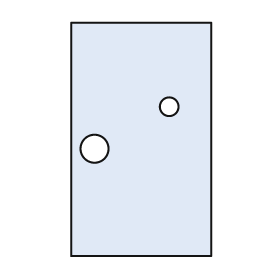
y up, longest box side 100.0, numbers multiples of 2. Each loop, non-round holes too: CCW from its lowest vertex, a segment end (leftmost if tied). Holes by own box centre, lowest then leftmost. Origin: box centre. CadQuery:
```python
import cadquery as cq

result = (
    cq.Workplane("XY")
    .moveTo(-30.0, -50.0)
    .lineTo(30.0, -50.0)
    .lineTo(30.0, 50.0)
    .lineTo(-30.0, 50.0)
    .close()
    .moveTo(-20.0, -4.0)
    .circle(6.0)
    .moveTo(12.0, 14.0)
    .circle(4.0)
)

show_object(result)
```